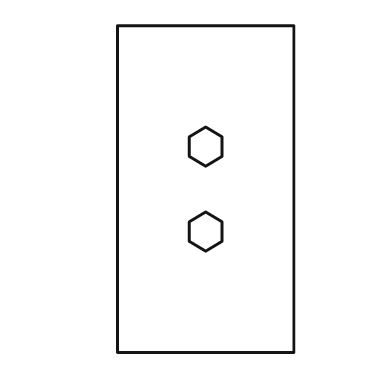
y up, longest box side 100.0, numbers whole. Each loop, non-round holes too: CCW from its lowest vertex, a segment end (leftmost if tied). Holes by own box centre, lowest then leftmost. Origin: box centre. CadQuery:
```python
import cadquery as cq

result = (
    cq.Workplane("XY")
    .moveTo(-27.0, -50.0)
    .lineTo(27.0, -50.0)
    .lineTo(27.0, 50.0)
    .lineTo(-27.0, 50.0)
    .close()
    .moveTo(0.0, -19.0)
    .lineTo(5.0, -16.0)
    .lineTo(5.0, -10.0)
    .lineTo(0.0, -7.0)
    .lineTo(-5.0, -10.0)
    .lineTo(-5.0, -16.0)
    .close()
    .moveTo(0.0, 7.0)
    .lineTo(5.0, 10.0)
    .lineTo(5.0, 16.0)
    .lineTo(0.0, 19.0)
    .lineTo(-5.0, 16.0)
    .lineTo(-5.0, 10.0)
    .close()
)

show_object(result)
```